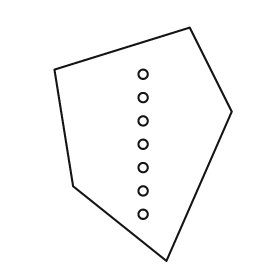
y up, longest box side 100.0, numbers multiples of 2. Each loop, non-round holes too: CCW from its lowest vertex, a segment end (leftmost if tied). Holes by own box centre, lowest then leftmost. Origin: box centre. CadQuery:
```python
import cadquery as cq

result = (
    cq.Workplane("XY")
    .moveTo(10.0, -50.0)
    .lineTo(38.0, 14.0)
    .lineTo(20.0, 50.0)
    .lineTo(-38.0, 32.0)
    .lineTo(-30.0, -18.0)
    .close()
    .moveTo(0.0, -30.0)
    .circle(2.0)
    .moveTo(0.0, -20.0)
    .circle(2.0)
    .moveTo(0.0, -10.0)
    .circle(2.0)
    .moveTo(0.0, 0.0)
    .circle(2.0)
    .moveTo(0.0, 10.0)
    .circle(2.0)
    .moveTo(0.0, 20.0)
    .circle(2.0)
    .moveTo(0.0, 30.0)
    .circle(2.0)
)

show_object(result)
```